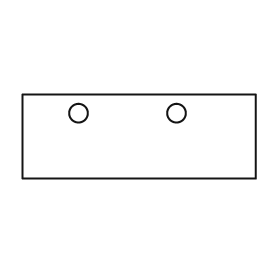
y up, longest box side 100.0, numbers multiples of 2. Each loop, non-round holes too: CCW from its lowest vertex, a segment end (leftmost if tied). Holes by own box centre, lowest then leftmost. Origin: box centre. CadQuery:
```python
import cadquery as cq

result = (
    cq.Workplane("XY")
    .moveTo(-50.0, -18.0)
    .lineTo(50.0, -18.0)
    .lineTo(50.0, 18.0)
    .lineTo(-50.0, 18.0)
    .close()
    .moveTo(-26.0, 10.0)
    .circle(4.0)
    .moveTo(16.0, 10.0)
    .circle(4.0)
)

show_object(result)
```